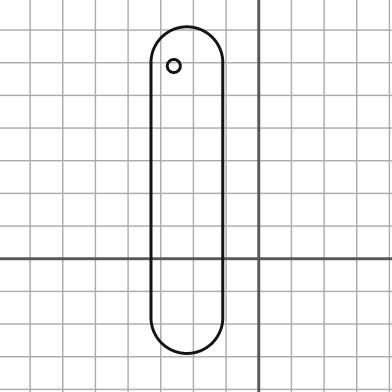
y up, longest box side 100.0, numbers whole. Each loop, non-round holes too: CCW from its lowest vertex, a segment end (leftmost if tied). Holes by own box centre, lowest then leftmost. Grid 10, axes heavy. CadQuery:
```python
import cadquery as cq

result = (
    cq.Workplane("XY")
    .moveTo(-33.0, -18.0)
    .threePointArc((-22.0, -29.0), (-11.0, -18.0))
    .lineTo(-11.0, 60.0)
    .threePointArc((-22.0, 71.0), (-33.0, 60.0))
    .close()
    .moveTo(-26.0, 59.0)
    .circle(2.0)
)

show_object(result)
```